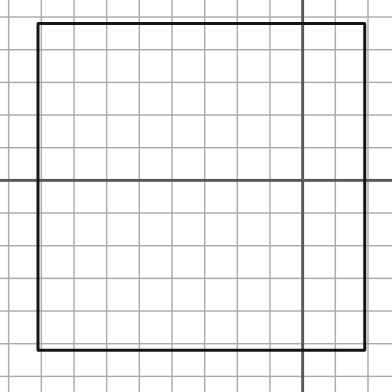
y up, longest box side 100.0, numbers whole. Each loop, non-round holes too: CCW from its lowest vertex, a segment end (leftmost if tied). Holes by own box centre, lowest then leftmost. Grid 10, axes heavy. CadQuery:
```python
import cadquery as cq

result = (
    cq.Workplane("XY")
    .moveTo(-81.0, -52.0)
    .lineTo(19.0, -52.0)
    .lineTo(19.0, 48.0)
    .lineTo(-81.0, 48.0)
    .close()
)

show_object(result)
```